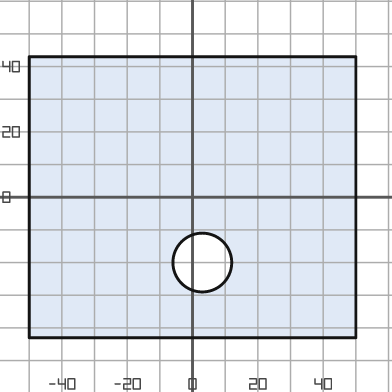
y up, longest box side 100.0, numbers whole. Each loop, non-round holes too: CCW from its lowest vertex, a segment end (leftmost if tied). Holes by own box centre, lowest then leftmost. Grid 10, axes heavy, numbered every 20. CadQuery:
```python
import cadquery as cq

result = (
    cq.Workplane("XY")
    .moveTo(-50.0, -43.0)
    .lineTo(50.0, -43.0)
    .lineTo(50.0, 43.0)
    .lineTo(-50.0, 43.0)
    .close()
    .moveTo(3.0, -20.0)
    .circle(9.0)
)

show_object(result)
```